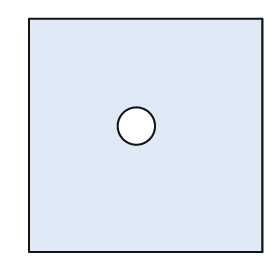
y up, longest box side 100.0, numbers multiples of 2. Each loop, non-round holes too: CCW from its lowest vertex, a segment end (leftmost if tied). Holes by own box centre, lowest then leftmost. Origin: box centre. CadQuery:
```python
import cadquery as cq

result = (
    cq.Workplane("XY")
    .moveTo(-50.0, -50.0)
    .lineTo(50.0, -50.0)
    .lineTo(50.0, 50.0)
    .lineTo(-50.0, 50.0)
    .close()
    .moveTo(-4.0, 4.0)
    .circle(8.0)
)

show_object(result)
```